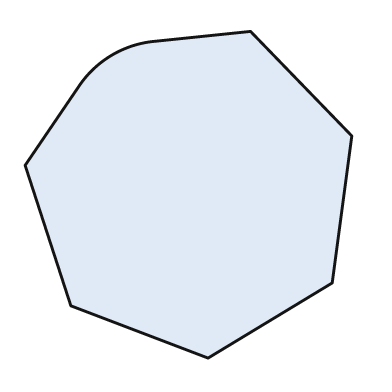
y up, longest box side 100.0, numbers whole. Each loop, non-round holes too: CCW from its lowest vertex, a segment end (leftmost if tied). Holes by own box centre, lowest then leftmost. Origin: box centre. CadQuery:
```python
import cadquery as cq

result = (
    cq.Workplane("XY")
    .moveTo(6.0, -50.0)
    .lineTo(44.0, -27.0)
    .lineTo(50.0, 18.0)
    .lineTo(19.0, 50.0)
    .lineTo(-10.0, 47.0)
    .threePointArc((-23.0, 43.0), (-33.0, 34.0))
    .lineTo(-50.0, 9.0)
    .lineTo(-36.0, -34.0)
    .close()
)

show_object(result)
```